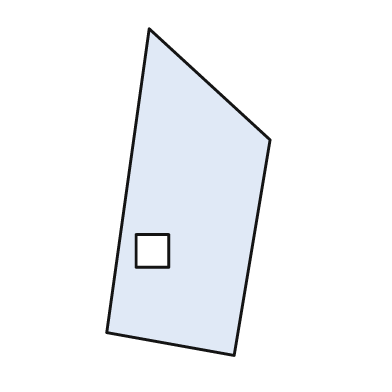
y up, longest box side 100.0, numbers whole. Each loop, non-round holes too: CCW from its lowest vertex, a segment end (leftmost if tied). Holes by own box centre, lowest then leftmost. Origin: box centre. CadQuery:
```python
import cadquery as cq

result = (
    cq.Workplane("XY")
    .moveTo(14.0, -50.0)
    .lineTo(25.0, 16.0)
    .lineTo(-12.0, 50.0)
    .lineTo(-25.0, -43.0)
    .close()
    .moveTo(-16.0, -23.0)
    .lineTo(-6.0, -23.0)
    .lineTo(-6.0, -13.0)
    .lineTo(-16.0, -13.0)
    .close()
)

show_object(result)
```